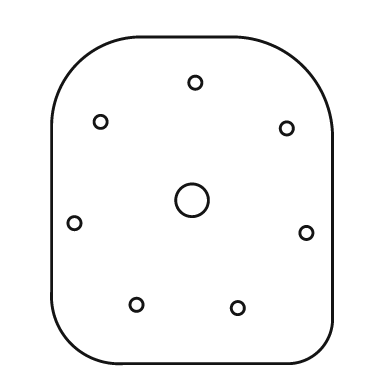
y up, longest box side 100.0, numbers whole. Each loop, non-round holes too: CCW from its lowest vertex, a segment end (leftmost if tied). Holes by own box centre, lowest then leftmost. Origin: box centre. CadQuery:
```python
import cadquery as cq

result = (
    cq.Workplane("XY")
    .moveTo(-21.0, -50.0)
    .lineTo(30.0, -50.0)
    .threePointArc((39.0, -46.0), (43.0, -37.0))
    .lineTo(43.0, 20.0)
    .threePointArc((34.0, 41.0), (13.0, 50.0))
    .lineTo(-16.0, 50.0)
    .threePointArc((-35.0, 42.0), (-43.0, 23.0))
    .lineTo(-43.0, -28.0)
    .threePointArc((-37.0, -44.0), (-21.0, -50.0))
    .close()
    .moveTo(14.0, -33.0)
    .circle(2.0)
    .moveTo(-17.0, -32.0)
    .circle(2.0)
    .moveTo(35.0, -10.0)
    .circle(2.0)
    .moveTo(-36.0, -7.0)
    .circle(2.0)
    .moveTo(0.0, 0.0)
    .circle(5.0)
    .moveTo(29.0, 22.0)
    .circle(2.0)
    .moveTo(-28.0, 24.0)
    .circle(2.0)
    .moveTo(1.0, 36.0)
    .circle(2.0)
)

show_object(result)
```